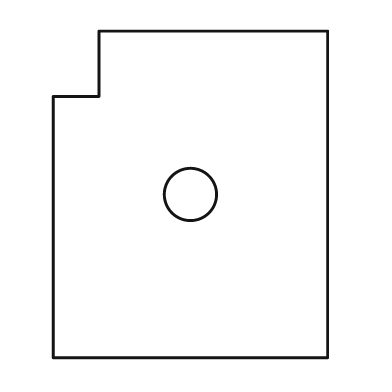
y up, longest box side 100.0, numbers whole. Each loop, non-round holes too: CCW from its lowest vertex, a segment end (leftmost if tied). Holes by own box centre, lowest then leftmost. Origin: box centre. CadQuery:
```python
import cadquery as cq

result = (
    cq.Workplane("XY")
    .moveTo(-42.0, -50.0)
    .lineTo(42.0, -50.0)
    .lineTo(42.0, 50.0)
    .lineTo(-28.0, 50.0)
    .lineTo(-28.0, 30.0)
    .lineTo(-42.0, 30.0)
    .close()
    .moveTo(0.0, 0.0)
    .circle(8.0)
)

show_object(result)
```